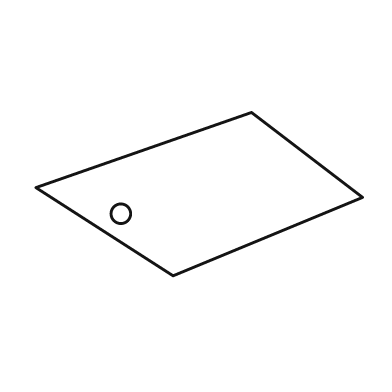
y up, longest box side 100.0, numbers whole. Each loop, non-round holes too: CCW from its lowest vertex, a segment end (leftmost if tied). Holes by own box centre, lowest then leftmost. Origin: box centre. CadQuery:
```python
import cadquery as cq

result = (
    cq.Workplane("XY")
    .moveTo(-8.0, -25.0)
    .lineTo(50.0, -1.0)
    .lineTo(16.0, 25.0)
    .lineTo(-50.0, 2.0)
    .close()
    .moveTo(-24.0, -6.0)
    .circle(3.0)
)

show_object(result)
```